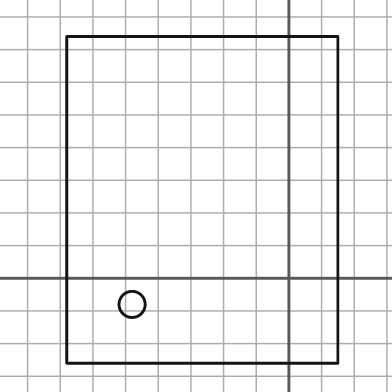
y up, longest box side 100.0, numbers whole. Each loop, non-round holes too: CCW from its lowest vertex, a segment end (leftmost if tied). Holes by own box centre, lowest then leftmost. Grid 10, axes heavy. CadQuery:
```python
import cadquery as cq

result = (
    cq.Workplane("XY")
    .moveTo(-68.0, -26.0)
    .lineTo(15.0, -26.0)
    .lineTo(15.0, 74.0)
    .lineTo(-68.0, 74.0)
    .close()
    .moveTo(-48.0, -8.0)
    .circle(4.0)
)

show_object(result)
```